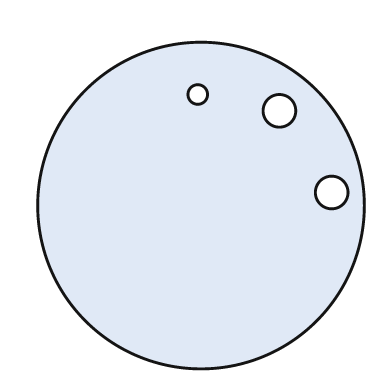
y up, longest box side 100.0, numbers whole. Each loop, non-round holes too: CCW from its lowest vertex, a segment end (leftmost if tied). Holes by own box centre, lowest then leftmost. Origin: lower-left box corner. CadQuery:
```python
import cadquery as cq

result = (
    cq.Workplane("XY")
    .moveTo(50.0, 50.0)
    .circle(50.0)
    .moveTo(90.0, 54.0)
    .circle(5.0)
    .moveTo(74.0, 79.0)
    .circle(5.0)
    .moveTo(49.0, 84.0)
    .circle(3.0)
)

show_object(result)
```